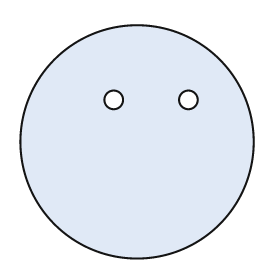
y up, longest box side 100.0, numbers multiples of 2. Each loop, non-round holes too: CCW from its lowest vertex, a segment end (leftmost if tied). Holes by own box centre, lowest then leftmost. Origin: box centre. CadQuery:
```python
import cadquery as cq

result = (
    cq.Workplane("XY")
    .moveTo(0.0, 0.0)
    .circle(50.0)
    .moveTo(-10.0, 18.0)
    .circle(4.0)
    .moveTo(22.0, 18.0)
    .circle(4.0)
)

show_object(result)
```